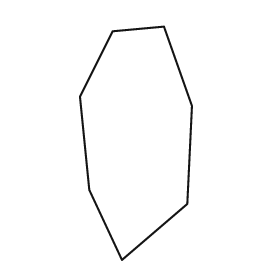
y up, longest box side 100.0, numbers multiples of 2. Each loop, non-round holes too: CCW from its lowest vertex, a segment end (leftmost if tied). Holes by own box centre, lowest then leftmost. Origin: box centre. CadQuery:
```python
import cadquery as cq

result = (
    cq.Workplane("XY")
    .moveTo(-6.0, -50.0)
    .lineTo(22.0, -26.0)
    .lineTo(24.0, 16.0)
    .lineTo(12.0, 50.0)
    .lineTo(-10.0, 48.0)
    .lineTo(-24.0, 20.0)
    .lineTo(-20.0, -20.0)
    .close()
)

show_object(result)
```